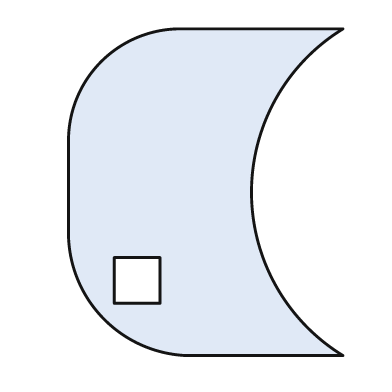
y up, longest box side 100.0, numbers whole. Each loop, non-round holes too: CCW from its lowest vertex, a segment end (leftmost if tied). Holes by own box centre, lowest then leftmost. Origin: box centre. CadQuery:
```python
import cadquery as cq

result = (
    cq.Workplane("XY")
    .moveTo(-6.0, -50.0)
    .lineTo(42.0, -50.0)
    .threePointArc((14.0, 0.0), (42.0, 50.0))
    .lineTo(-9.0, 50.0)
    .threePointArc((-32.0, 40.0), (-42.0, 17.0))
    .lineTo(-42.0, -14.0)
    .threePointArc((-31.0, -39.0), (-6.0, -50.0))
    .close()
    .moveTo(-28.0, -34.0)
    .lineTo(-14.0, -34.0)
    .lineTo(-14.0, -20.0)
    .lineTo(-28.0, -20.0)
    .close()
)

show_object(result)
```